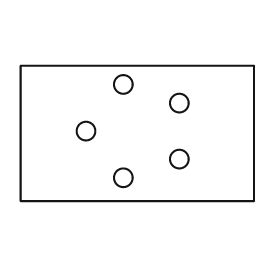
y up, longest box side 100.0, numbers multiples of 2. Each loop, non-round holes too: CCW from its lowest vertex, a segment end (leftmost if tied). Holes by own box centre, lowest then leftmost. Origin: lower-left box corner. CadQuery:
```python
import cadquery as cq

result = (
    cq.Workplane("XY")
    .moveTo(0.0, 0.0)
    .lineTo(100.0, 0.0)
    .lineTo(100.0, 58.0)
    .lineTo(0.0, 58.0)
    .close()
    .moveTo(44.0, 10.0)
    .circle(4.0)
    .moveTo(68.0, 18.0)
    .circle(4.0)
    .moveTo(28.0, 30.0)
    .circle(4.0)
    .moveTo(68.0, 42.0)
    .circle(4.0)
    .moveTo(44.0, 50.0)
    .circle(4.0)
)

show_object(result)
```